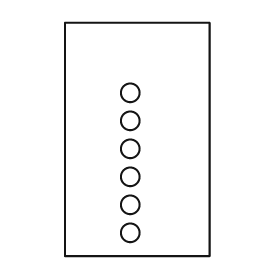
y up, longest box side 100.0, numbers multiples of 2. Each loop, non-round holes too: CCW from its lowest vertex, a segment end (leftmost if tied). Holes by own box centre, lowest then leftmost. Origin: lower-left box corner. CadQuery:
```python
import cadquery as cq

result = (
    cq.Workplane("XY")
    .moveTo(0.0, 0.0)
    .lineTo(62.0, 0.0)
    .lineTo(62.0, 100.0)
    .lineTo(0.0, 100.0)
    .close()
    .moveTo(28.0, 10.0)
    .circle(4.0)
    .moveTo(28.0, 22.0)
    .circle(4.0)
    .moveTo(28.0, 34.0)
    .circle(4.0)
    .moveTo(28.0, 46.0)
    .circle(4.0)
    .moveTo(28.0, 58.0)
    .circle(4.0)
    .moveTo(28.0, 70.0)
    .circle(4.0)
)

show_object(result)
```